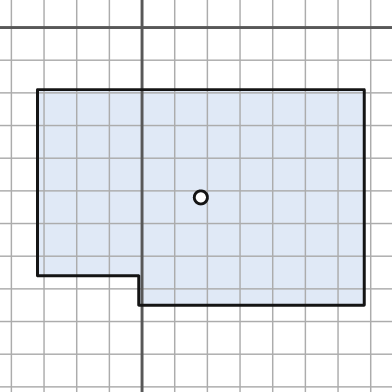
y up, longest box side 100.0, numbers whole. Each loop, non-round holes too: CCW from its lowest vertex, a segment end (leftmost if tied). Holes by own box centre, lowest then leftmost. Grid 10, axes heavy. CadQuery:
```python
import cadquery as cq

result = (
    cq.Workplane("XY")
    .moveTo(-1.0, -85.0)
    .lineTo(68.0, -85.0)
    .lineTo(68.0, -19.0)
    .lineTo(-32.0, -19.0)
    .lineTo(-32.0, -76.0)
    .lineTo(-1.0, -76.0)
    .close()
    .moveTo(18.0, -52.0)
    .circle(2.0)
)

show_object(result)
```